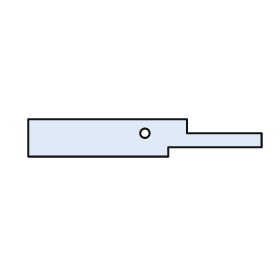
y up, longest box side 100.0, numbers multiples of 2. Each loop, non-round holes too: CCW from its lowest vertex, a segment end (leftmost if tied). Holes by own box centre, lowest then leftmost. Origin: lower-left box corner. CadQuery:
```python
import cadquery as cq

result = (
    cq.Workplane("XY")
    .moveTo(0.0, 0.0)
    .lineTo(60.0, 0.0)
    .lineTo(60.0, 4.0)
    .lineTo(100.0, 4.0)
    .lineTo(100.0, 10.0)
    .lineTo(68.0, 10.0)
    .lineTo(68.0, 16.0)
    .lineTo(0.0, 16.0)
    .close()
    .moveTo(50.0, 10.0)
    .circle(2.0)
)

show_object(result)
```